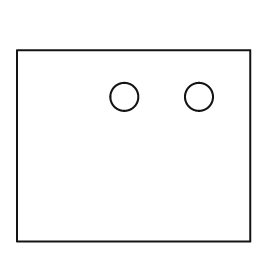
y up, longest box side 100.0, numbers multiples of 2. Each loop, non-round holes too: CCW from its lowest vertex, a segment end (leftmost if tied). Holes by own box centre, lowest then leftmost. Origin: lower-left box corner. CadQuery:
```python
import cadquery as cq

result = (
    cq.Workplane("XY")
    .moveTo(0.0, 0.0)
    .lineTo(100.0, 0.0)
    .lineTo(100.0, 82.0)
    .lineTo(0.0, 82.0)
    .close()
    .moveTo(46.0, 62.0)
    .circle(6.0)
    .moveTo(78.0, 62.0)
    .circle(6.0)
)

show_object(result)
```